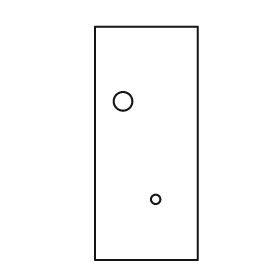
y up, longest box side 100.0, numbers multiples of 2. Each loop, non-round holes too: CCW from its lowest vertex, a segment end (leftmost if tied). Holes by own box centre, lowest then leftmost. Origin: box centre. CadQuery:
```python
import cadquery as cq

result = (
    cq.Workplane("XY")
    .moveTo(-22.0, -50.0)
    .lineTo(22.0, -50.0)
    .lineTo(22.0, 50.0)
    .lineTo(-22.0, 50.0)
    .close()
    .moveTo(4.0, -24.0)
    .circle(2.0)
    .moveTo(-10.0, 18.0)
    .circle(4.0)
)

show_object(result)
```